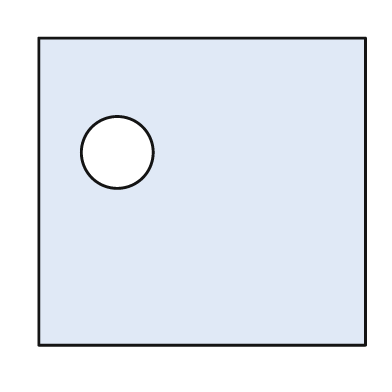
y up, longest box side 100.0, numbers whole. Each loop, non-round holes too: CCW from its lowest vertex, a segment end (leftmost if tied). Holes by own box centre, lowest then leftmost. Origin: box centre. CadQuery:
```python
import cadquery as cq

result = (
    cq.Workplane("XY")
    .moveTo(-50.0, -47.0)
    .lineTo(50.0, -47.0)
    .lineTo(50.0, 47.0)
    .lineTo(-50.0, 47.0)
    .close()
    .moveTo(-26.0, 12.0)
    .circle(11.0)
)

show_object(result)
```